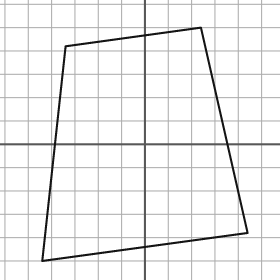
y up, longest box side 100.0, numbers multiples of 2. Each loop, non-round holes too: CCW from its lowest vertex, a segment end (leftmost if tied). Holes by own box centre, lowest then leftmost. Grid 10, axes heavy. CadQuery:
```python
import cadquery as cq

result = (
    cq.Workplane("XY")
    .moveTo(-44.0, -50.0)
    .lineTo(44.0, -38.0)
    .lineTo(24.0, 50.0)
    .lineTo(-34.0, 42.0)
    .close()
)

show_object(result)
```